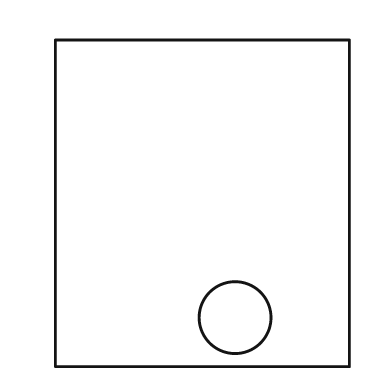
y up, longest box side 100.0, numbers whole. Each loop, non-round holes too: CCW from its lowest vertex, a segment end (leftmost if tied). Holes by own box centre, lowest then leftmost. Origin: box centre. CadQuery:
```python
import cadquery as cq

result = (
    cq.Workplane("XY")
    .moveTo(-45.0, -50.0)
    .lineTo(45.0, -50.0)
    .lineTo(45.0, 50.0)
    .lineTo(-45.0, 50.0)
    .close()
    .moveTo(10.0, -35.0)
    .circle(11.0)
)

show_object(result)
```